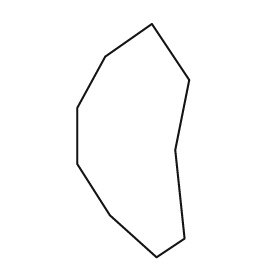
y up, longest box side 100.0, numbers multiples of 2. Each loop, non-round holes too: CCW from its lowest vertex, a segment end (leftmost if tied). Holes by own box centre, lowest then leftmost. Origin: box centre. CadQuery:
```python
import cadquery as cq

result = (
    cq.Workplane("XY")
    .moveTo(10.0, -50.0)
    .lineTo(22.0, -42.0)
    .lineTo(18.0, -4.0)
    .lineTo(24.0, 26.0)
    .lineTo(8.0, 50.0)
    .lineTo(-12.0, 36.0)
    .lineTo(-24.0, 14.0)
    .lineTo(-24.0, -10.0)
    .lineTo(-10.0, -32.0)
    .close()
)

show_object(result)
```